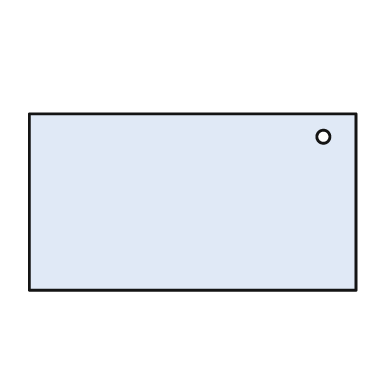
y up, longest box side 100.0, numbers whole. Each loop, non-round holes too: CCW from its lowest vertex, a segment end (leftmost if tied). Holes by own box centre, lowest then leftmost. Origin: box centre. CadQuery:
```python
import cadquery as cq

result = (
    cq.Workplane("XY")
    .moveTo(-50.0, -27.0)
    .lineTo(50.0, -27.0)
    .lineTo(50.0, 27.0)
    .lineTo(-50.0, 27.0)
    .close()
    .moveTo(40.0, 20.0)
    .circle(2.0)
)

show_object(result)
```